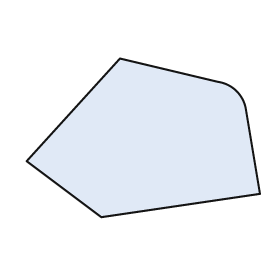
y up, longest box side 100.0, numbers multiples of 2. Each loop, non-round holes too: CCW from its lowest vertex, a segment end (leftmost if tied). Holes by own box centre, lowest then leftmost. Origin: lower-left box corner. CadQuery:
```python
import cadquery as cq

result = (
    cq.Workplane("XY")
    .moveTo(32.0, 0.0)
    .lineTo(100.0, 10.0)
    .lineTo(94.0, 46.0)
    .threePointArc((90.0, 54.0), (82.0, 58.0))
    .lineTo(40.0, 68.0)
    .lineTo(0.0, 24.0)
    .close()
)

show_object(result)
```